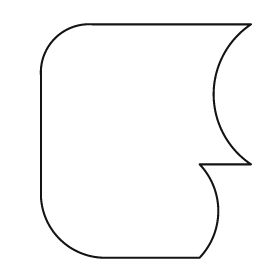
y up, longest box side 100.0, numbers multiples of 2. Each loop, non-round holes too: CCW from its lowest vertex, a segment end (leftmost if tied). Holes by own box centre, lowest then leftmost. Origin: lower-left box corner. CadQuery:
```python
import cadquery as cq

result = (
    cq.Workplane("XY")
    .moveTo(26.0, 0.0)
    .lineTo(68.0, 0.0)
    .threePointArc((76.0, 20.0), (68.0, 40.0))
    .lineTo(90.0, 40.0)
    .threePointArc((74.0, 70.0), (90.0, 100.0))
    .lineTo(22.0, 100.0)
    .threePointArc((6.0, 94.0), (0.0, 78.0))
    .lineTo(0.0, 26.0)
    .threePointArc((8.0, 8.0), (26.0, 0.0))
    .close()
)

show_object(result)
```